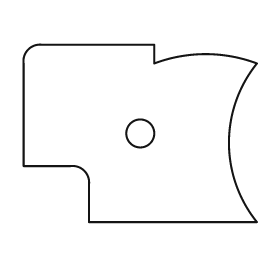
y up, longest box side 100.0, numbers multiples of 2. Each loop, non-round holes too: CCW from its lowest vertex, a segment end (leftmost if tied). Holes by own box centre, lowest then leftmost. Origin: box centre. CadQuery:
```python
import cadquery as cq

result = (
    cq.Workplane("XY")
    .moveTo(-22.0, -38.0)
    .lineTo(50.0, -38.0)
    .threePointArc((38.0, -4.0), (50.0, 30.0))
    .threePointArc((28.0, 34.0), (6.0, 30.0))
    .lineTo(6.0, 38.0)
    .lineTo(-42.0, 38.0)
    .threePointArc((-48.0, 36.0), (-50.0, 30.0))
    .lineTo(-50.0, -14.0)
    .lineTo(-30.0, -14.0)
    .threePointArc((-24.0, -16.0), (-22.0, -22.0))
    .close()
    .moveTo(0.0, 0.0)
    .circle(6.0)
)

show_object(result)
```